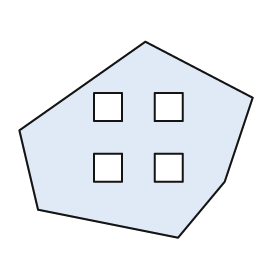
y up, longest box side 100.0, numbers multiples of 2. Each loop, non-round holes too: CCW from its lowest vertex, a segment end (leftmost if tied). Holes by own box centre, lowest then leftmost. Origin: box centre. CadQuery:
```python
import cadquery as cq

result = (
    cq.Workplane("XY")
    .moveTo(18.0, -42.0)
    .lineTo(38.0, -18.0)
    .lineTo(50.0, 18.0)
    .lineTo(4.0, 42.0)
    .lineTo(-50.0, 4.0)
    .lineTo(-42.0, -30.0)
    .close()
    .moveTo(-18.0, -18.0)
    .lineTo(-6.0, -18.0)
    .lineTo(-6.0, -6.0)
    .lineTo(-18.0, -6.0)
    .close()
    .moveTo(8.0, -18.0)
    .lineTo(20.0, -18.0)
    .lineTo(20.0, -6.0)
    .lineTo(8.0, -6.0)
    .close()
    .moveTo(-18.0, 8.0)
    .lineTo(-6.0, 8.0)
    .lineTo(-6.0, 20.0)
    .lineTo(-18.0, 20.0)
    .close()
    .moveTo(8.0, 8.0)
    .lineTo(20.0, 8.0)
    .lineTo(20.0, 20.0)
    .lineTo(8.0, 20.0)
    .close()
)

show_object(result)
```